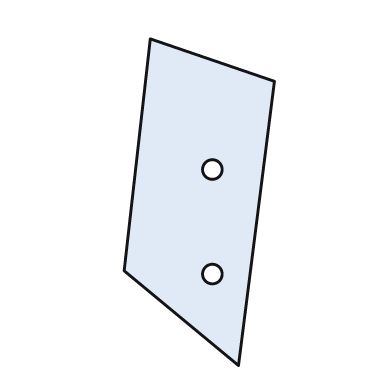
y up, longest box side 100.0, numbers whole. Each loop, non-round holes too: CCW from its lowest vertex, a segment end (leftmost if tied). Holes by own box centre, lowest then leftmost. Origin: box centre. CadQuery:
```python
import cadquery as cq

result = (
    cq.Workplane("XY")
    .moveTo(12.0, -50.0)
    .lineTo(23.0, 37.0)
    .lineTo(-15.0, 50.0)
    .lineTo(-23.0, -21.0)
    .close()
    .moveTo(4.0, -22.0)
    .circle(3.0)
    .moveTo(4.0, 10.0)
    .circle(3.0)
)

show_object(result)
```